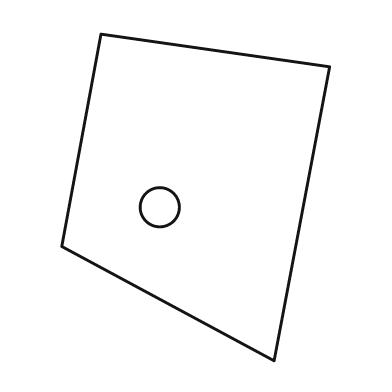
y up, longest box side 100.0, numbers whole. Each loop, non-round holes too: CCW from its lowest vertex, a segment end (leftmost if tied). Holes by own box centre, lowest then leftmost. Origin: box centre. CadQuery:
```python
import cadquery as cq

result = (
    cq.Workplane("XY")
    .moveTo(24.0, -50.0)
    .lineTo(41.0, 40.0)
    .lineTo(-29.0, 50.0)
    .lineTo(-41.0, -15.0)
    .close()
    .moveTo(-11.0, -3.0)
    .circle(6.0)
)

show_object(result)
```